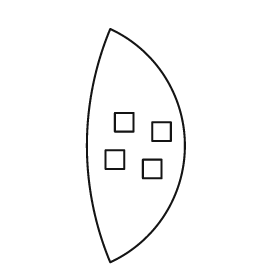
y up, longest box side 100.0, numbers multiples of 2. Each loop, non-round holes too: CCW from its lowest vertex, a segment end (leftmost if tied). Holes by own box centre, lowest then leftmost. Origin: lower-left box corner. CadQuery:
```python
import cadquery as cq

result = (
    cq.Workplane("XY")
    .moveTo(10.0, 0.0)
    .threePointArc((42.0, 50.0), (10.0, 100.0))
    .threePointArc((0.0, 50.0), (10.0, 0.0))
    .close()
    .moveTo(24.0, 36.0)
    .lineTo(32.0, 36.0)
    .lineTo(32.0, 44.0)
    .lineTo(24.0, 44.0)
    .close()
    .moveTo(8.0, 40.0)
    .lineTo(16.0, 40.0)
    .lineTo(16.0, 48.0)
    .lineTo(8.0, 48.0)
    .close()
    .moveTo(28.0, 52.0)
    .lineTo(36.0, 52.0)
    .lineTo(36.0, 60.0)
    .lineTo(28.0, 60.0)
    .close()
    .moveTo(12.0, 56.0)
    .lineTo(20.0, 56.0)
    .lineTo(20.0, 64.0)
    .lineTo(12.0, 64.0)
    .close()
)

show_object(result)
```